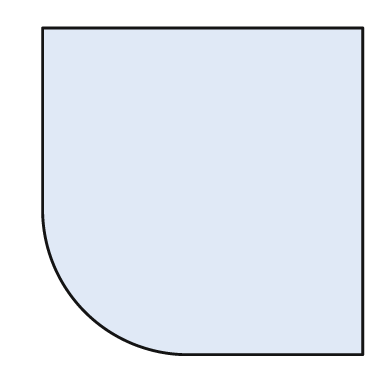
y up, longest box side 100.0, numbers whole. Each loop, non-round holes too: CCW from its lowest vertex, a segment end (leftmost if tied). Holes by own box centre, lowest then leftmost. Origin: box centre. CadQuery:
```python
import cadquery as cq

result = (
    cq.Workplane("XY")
    .moveTo(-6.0, -50.0)
    .lineTo(49.0, -50.0)
    .lineTo(49.0, 50.0)
    .lineTo(-49.0, 50.0)
    .lineTo(-49.0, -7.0)
    .threePointArc((-36.0, -37.0), (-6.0, -50.0))
    .close()
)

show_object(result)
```